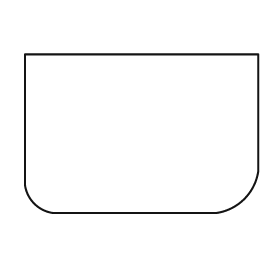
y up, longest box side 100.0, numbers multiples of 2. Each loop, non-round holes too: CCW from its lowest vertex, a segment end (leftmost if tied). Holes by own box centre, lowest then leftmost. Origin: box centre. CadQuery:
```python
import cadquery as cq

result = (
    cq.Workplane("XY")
    .moveTo(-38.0, -34.0)
    .lineTo(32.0, -34.0)
    .threePointArc((44.0, -28.0), (50.0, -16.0))
    .lineTo(50.0, 34.0)
    .lineTo(-50.0, 34.0)
    .lineTo(-50.0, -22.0)
    .threePointArc((-46.0, -30.0), (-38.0, -34.0))
    .close()
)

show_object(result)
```